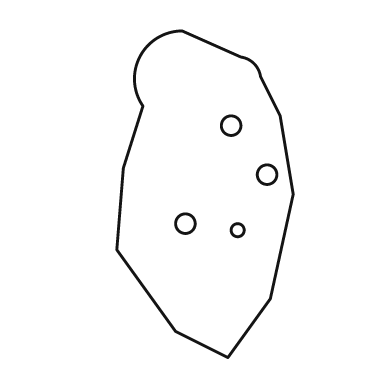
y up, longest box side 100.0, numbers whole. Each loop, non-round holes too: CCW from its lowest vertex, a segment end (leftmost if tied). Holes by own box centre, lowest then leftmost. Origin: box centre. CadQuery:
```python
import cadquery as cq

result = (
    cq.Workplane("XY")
    .moveTo(7.0, -50.0)
    .lineTo(20.0, -32.0)
    .lineTo(27.0, 0.0)
    .lineTo(23.0, 24.0)
    .lineTo(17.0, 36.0)
    .threePointArc((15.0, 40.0), (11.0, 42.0))
    .lineTo(-7.0, 50.0)
    .threePointArc((-20.0, 42.0), (-19.0, 27.0))
    .lineTo(-25.0, 8.0)
    .lineTo(-27.0, -17.0)
    .lineTo(-9.0, -42.0)
    .close()
    .moveTo(10.0, -11.0)
    .circle(2.0)
    .moveTo(-6.0, -9.0)
    .circle(3.0)
    .moveTo(19.0, 6.0)
    .circle(3.0)
    .moveTo(8.0, 21.0)
    .circle(3.0)
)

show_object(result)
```